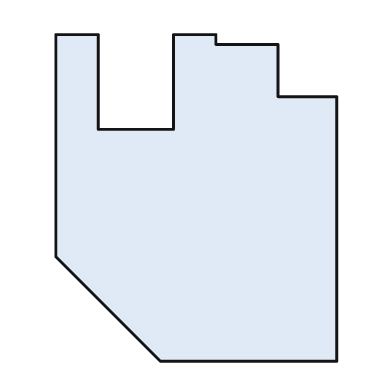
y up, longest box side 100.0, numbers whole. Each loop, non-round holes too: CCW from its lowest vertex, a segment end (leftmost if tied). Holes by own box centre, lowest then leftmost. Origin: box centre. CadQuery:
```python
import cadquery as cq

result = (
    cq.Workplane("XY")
    .moveTo(-11.0, -50.0)
    .lineTo(43.0, -50.0)
    .lineTo(43.0, 31.0)
    .lineTo(25.0, 31.0)
    .lineTo(25.0, 47.0)
    .lineTo(6.0, 47.0)
    .lineTo(6.0, 50.0)
    .lineTo(-7.0, 50.0)
    .lineTo(-7.0, 21.0)
    .lineTo(-30.0, 21.0)
    .lineTo(-30.0, 50.0)
    .lineTo(-43.0, 50.0)
    .lineTo(-43.0, -18.0)
    .close()
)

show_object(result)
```